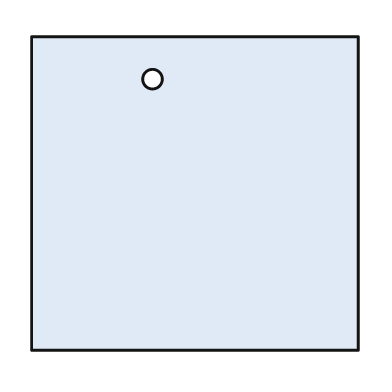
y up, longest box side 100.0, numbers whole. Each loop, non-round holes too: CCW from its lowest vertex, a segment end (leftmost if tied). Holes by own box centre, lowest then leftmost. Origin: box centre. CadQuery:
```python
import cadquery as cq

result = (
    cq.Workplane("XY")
    .moveTo(-50.0, -48.0)
    .lineTo(50.0, -48.0)
    .lineTo(50.0, 48.0)
    .lineTo(-50.0, 48.0)
    .close()
    .moveTo(-13.0, 35.0)
    .circle(3.0)
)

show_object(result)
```